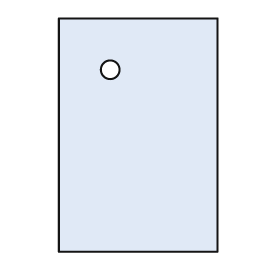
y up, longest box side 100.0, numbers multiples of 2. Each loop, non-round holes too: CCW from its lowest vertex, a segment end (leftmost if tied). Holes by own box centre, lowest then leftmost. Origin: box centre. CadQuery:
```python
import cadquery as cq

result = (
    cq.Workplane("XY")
    .moveTo(-34.0, -50.0)
    .lineTo(34.0, -50.0)
    .lineTo(34.0, 50.0)
    .lineTo(-34.0, 50.0)
    .close()
    .moveTo(-12.0, 28.0)
    .circle(4.0)
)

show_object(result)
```